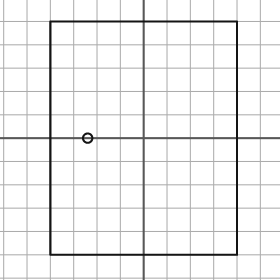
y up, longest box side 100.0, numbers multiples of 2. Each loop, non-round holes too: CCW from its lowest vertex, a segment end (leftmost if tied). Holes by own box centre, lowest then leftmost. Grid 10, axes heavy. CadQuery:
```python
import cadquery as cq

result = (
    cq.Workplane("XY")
    .moveTo(-40.0, -50.0)
    .lineTo(40.0, -50.0)
    .lineTo(40.0, 50.0)
    .lineTo(-40.0, 50.0)
    .close()
    .moveTo(-24.0, 0.0)
    .circle(2.0)
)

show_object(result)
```